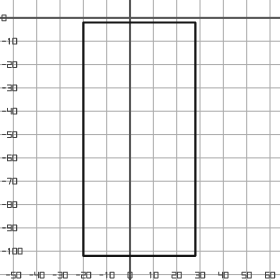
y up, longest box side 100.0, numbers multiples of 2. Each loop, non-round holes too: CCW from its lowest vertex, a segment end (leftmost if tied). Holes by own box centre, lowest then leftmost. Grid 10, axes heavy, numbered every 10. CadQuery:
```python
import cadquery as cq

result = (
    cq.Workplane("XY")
    .moveTo(-20.0, -102.0)
    .lineTo(28.0, -102.0)
    .lineTo(28.0, -2.0)
    .lineTo(-20.0, -2.0)
    .close()
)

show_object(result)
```